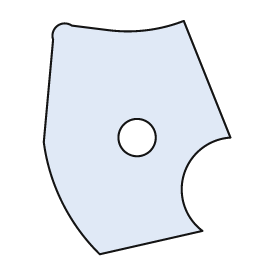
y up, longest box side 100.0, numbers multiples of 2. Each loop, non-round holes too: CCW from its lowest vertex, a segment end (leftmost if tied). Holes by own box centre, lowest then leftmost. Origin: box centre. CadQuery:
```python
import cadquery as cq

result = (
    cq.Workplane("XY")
    .moveTo(-16.0, -50.0)
    .lineTo(28.0, -40.0)
    .threePointArc((20.0, -16.0), (40.0, 0.0))
    .lineTo(20.0, 50.0)
    .threePointArc((4.0, 46.0), (-12.0, 46.0))
    .lineTo(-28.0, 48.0)
    .threePointArc((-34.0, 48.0), (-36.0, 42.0))
    .lineTo(-40.0, -2.0)
    .threePointArc((-32.0, -28.0), (-16.0, -50.0))
    .close()
    .moveTo(0.0, 0.0)
    .circle(8.0)
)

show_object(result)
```